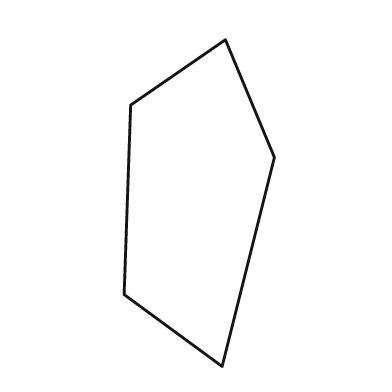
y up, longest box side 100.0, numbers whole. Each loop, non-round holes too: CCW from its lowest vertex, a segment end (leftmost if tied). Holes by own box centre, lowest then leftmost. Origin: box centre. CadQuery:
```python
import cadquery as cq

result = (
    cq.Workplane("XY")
    .moveTo(7.0, -50.0)
    .lineTo(23.0, 14.0)
    .lineTo(8.0, 50.0)
    .lineTo(-21.0, 30.0)
    .lineTo(-23.0, -28.0)
    .close()
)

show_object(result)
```